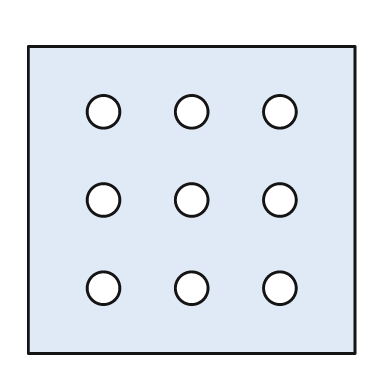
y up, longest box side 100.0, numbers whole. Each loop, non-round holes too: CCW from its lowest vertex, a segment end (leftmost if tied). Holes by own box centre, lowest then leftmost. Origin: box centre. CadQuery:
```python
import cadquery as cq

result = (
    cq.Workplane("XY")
    .moveTo(-50.0, -47.0)
    .lineTo(50.0, -47.0)
    .lineTo(50.0, 47.0)
    .lineTo(-50.0, 47.0)
    .close()
    .moveTo(-27.0, -27.0)
    .circle(5.0)
    .moveTo(0.0, -27.0)
    .circle(5.0)
    .moveTo(27.0, -27.0)
    .circle(5.0)
    .moveTo(-27.0, 0.0)
    .circle(5.0)
    .moveTo(0.0, 0.0)
    .circle(5.0)
    .moveTo(27.0, 0.0)
    .circle(5.0)
    .moveTo(-27.0, 27.0)
    .circle(5.0)
    .moveTo(0.0, 27.0)
    .circle(5.0)
    .moveTo(27.0, 27.0)
    .circle(5.0)
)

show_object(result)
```